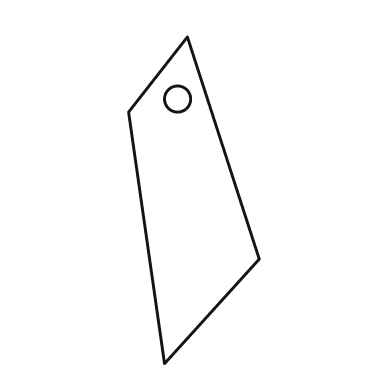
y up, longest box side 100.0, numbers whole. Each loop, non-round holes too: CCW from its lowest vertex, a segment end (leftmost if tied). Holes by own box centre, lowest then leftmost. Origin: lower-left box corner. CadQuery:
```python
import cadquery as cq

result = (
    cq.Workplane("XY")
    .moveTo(11.0, 0.0)
    .lineTo(40.0, 32.0)
    .lineTo(18.0, 100.0)
    .lineTo(0.0, 77.0)
    .close()
    .moveTo(15.0, 81.0)
    .circle(4.0)
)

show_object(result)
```